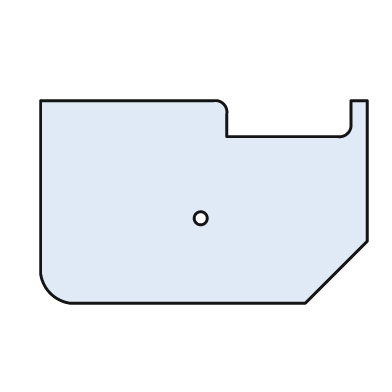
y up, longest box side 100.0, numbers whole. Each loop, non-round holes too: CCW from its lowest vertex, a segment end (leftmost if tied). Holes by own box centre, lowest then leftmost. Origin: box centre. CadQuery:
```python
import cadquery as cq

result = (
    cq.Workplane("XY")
    .moveTo(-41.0, -31.0)
    .lineTo(31.0, -31.0)
    .lineTo(50.0, -12.0)
    .lineTo(50.0, 31.0)
    .lineTo(45.0, 31.0)
    .lineTo(45.0, 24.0)
    .threePointArc((44.0, 21.0), (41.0, 20.0))
    .lineTo(7.0, 20.0)
    .lineTo(7.0, 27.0)
    .threePointArc((6.0, 30.0), (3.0, 31.0))
    .lineTo(-50.0, 31.0)
    .lineTo(-50.0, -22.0)
    .threePointArc((-47.0, -28.0), (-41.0, -31.0))
    .close()
    .moveTo(-1.0, -5.0)
    .circle(2.0)
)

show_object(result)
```